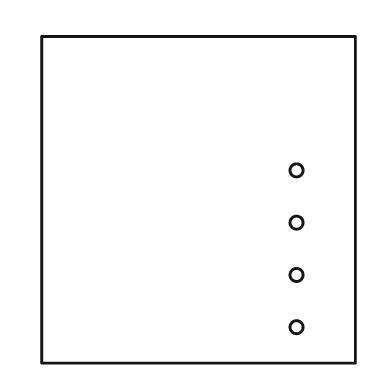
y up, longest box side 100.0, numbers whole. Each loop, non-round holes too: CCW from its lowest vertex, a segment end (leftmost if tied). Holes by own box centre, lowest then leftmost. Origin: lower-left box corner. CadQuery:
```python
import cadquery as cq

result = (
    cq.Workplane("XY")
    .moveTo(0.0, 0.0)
    .lineTo(96.0, 0.0)
    .lineTo(96.0, 100.0)
    .lineTo(0.0, 100.0)
    .close()
    .moveTo(78.0, 11.0)
    .circle(2.0)
    .moveTo(78.0, 27.0)
    .circle(2.0)
    .moveTo(78.0, 43.0)
    .circle(2.0)
    .moveTo(78.0, 59.0)
    .circle(2.0)
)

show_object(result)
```